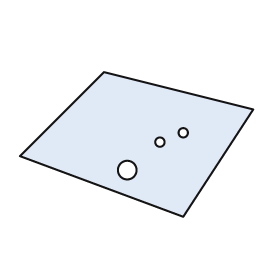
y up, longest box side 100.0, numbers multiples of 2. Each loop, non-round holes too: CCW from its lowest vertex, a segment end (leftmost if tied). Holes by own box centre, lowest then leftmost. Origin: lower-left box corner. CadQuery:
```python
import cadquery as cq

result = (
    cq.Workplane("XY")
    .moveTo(70.0, 0.0)
    .lineTo(100.0, 46.0)
    .lineTo(36.0, 62.0)
    .lineTo(0.0, 26.0)
    .close()
    .moveTo(46.0, 20.0)
    .circle(4.0)
    .moveTo(60.0, 32.0)
    .circle(2.0)
    .moveTo(70.0, 36.0)
    .circle(2.0)
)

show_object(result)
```